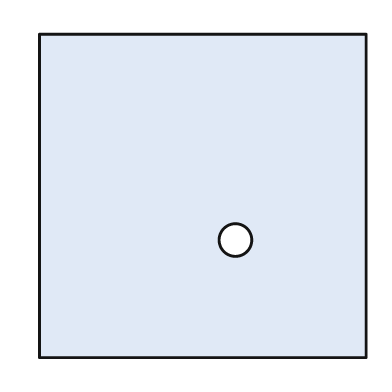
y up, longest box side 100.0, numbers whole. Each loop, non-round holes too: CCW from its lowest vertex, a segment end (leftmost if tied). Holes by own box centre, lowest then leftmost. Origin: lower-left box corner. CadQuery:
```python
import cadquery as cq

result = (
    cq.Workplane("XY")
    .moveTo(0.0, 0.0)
    .lineTo(100.0, 0.0)
    .lineTo(100.0, 99.0)
    .lineTo(0.0, 99.0)
    .close()
    .moveTo(60.0, 36.0)
    .circle(5.0)
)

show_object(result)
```